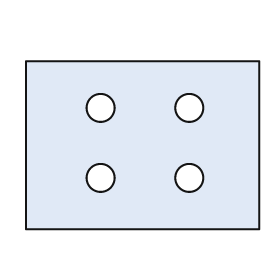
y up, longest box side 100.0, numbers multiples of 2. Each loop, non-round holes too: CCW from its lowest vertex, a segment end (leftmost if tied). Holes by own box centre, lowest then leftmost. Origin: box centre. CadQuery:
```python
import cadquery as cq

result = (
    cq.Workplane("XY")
    .moveTo(-50.0, -36.0)
    .lineTo(50.0, -36.0)
    .lineTo(50.0, 36.0)
    .lineTo(-50.0, 36.0)
    .close()
    .moveTo(-18.0, -14.0)
    .circle(6.0)
    .moveTo(20.0, -14.0)
    .circle(6.0)
    .moveTo(-18.0, 16.0)
    .circle(6.0)
    .moveTo(20.0, 16.0)
    .circle(6.0)
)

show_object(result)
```